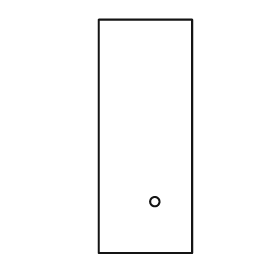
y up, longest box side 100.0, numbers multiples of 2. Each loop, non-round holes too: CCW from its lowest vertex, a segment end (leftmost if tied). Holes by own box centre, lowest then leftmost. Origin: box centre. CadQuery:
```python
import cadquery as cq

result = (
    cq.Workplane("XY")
    .moveTo(-20.0, -50.0)
    .lineTo(20.0, -50.0)
    .lineTo(20.0, 50.0)
    .lineTo(-20.0, 50.0)
    .close()
    .moveTo(4.0, -28.0)
    .circle(2.0)
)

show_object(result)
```